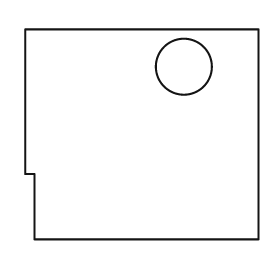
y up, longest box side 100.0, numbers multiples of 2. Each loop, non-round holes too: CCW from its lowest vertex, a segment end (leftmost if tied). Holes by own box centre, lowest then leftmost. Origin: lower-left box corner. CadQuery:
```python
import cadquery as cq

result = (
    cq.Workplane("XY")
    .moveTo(4.0, 0.0)
    .lineTo(100.0, 0.0)
    .lineTo(100.0, 90.0)
    .lineTo(0.0, 90.0)
    .lineTo(0.0, 28.0)
    .lineTo(4.0, 28.0)
    .close()
    .moveTo(68.0, 74.0)
    .circle(12.0)
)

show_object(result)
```